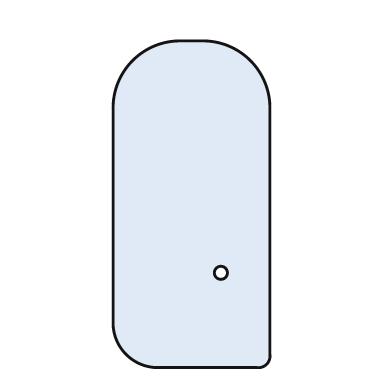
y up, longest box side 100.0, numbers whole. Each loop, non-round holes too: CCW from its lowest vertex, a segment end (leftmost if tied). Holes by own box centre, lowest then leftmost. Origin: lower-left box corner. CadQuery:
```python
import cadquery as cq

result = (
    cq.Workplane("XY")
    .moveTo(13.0, 0.0)
    .lineTo(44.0, 0.0)
    .threePointArc((47.0, 1.0), (48.0, 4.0))
    .lineTo(48.0, 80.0)
    .threePointArc((42.0, 94.0), (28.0, 100.0))
    .lineTo(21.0, 100.0)
    .threePointArc((6.0, 94.0), (0.0, 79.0))
    .lineTo(0.0, 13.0)
    .threePointArc((4.0, 4.0), (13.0, 0.0))
    .close()
    .moveTo(33.0, 29.0)
    .circle(2.0)
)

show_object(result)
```